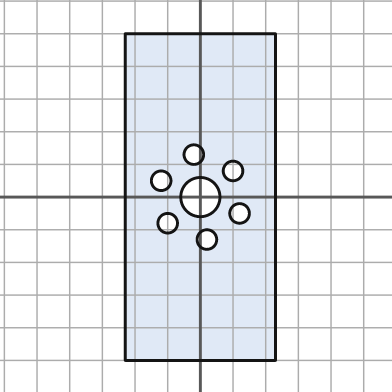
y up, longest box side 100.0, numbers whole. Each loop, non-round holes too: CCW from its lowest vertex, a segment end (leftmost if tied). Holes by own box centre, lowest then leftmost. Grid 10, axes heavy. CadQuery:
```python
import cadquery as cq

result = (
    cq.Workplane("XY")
    .moveTo(-23.0, -50.0)
    .lineTo(23.0, -50.0)
    .lineTo(23.0, 50.0)
    .lineTo(-23.0, 50.0)
    .close()
    .moveTo(2.0, -13.0)
    .circle(3.0)
    .moveTo(-10.0, -8.0)
    .circle(3.0)
    .moveTo(12.0, -5.0)
    .circle(3.0)
    .moveTo(0.0, 0.0)
    .circle(6.0)
    .moveTo(-12.0, 5.0)
    .circle(3.0)
    .moveTo(10.0, 8.0)
    .circle(3.0)
    .moveTo(-2.0, 13.0)
    .circle(3.0)
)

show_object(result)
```